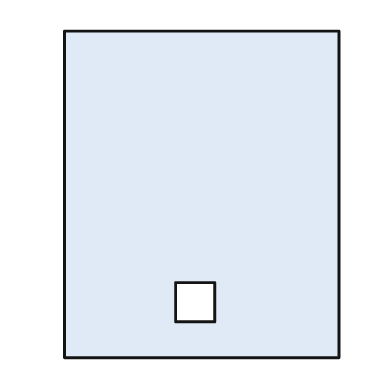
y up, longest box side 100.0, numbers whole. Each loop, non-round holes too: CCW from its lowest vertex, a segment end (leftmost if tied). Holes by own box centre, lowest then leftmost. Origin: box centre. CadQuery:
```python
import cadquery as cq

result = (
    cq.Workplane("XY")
    .moveTo(-42.0, -50.0)
    .lineTo(42.0, -50.0)
    .lineTo(42.0, 50.0)
    .lineTo(-42.0, 50.0)
    .close()
    .moveTo(-8.0, -39.0)
    .lineTo(4.0, -39.0)
    .lineTo(4.0, -27.0)
    .lineTo(-8.0, -27.0)
    .close()
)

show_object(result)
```